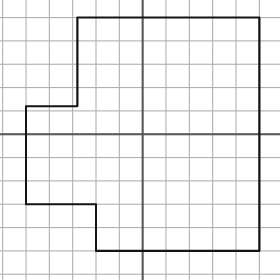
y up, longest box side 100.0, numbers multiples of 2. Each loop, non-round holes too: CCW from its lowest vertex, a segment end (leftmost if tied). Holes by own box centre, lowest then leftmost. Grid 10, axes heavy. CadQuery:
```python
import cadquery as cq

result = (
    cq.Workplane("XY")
    .moveTo(-20.0, -50.0)
    .lineTo(50.0, -50.0)
    .lineTo(50.0, 50.0)
    .lineTo(-28.0, 50.0)
    .lineTo(-28.0, 12.0)
    .lineTo(-50.0, 12.0)
    .lineTo(-50.0, -30.0)
    .lineTo(-20.0, -30.0)
    .close()
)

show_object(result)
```